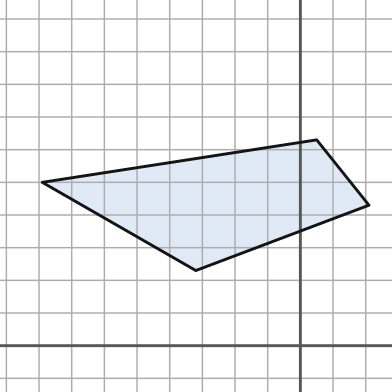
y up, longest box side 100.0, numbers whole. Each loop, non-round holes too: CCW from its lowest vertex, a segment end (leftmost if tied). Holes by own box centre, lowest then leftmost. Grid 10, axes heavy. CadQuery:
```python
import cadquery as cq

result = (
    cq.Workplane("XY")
    .moveTo(-32.0, 23.0)
    .lineTo(21.0, 43.0)
    .lineTo(5.0, 63.0)
    .lineTo(-79.0, 50.0)
    .close()
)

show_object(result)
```